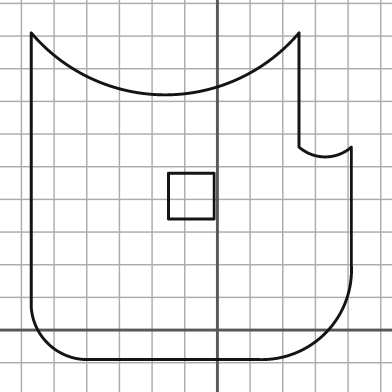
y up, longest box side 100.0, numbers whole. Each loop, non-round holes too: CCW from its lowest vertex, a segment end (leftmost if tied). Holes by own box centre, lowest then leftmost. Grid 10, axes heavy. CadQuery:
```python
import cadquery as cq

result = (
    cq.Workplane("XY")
    .moveTo(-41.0, -9.0)
    .lineTo(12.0, -9.0)
    .threePointArc((33.0, -1.0), (41.0, 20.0))
    .lineTo(41.0, 56.0)
    .threePointArc((33.0, 53.0), (25.0, 56.0))
    .lineTo(25.0, 91.0)
    .threePointArc((-16.0, 72.0), (-57.0, 91.0))
    .lineTo(-57.0, 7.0)
    .threePointArc((-52.0, -4.0), (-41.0, -9.0))
    .close()
    .moveTo(-15.0, 34.0)
    .lineTo(-1.0, 34.0)
    .lineTo(-1.0, 48.0)
    .lineTo(-15.0, 48.0)
    .close()
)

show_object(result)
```